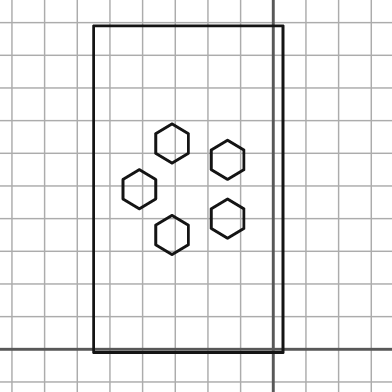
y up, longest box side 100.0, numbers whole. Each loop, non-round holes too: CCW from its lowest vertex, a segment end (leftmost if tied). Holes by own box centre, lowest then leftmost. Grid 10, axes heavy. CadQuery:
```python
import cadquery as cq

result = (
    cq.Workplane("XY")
    .moveTo(-55.0, -1.0)
    .lineTo(3.0, -1.0)
    .lineTo(3.0, 99.0)
    .lineTo(-55.0, 99.0)
    .close()
    .moveTo(-31.0, 29.0)
    .lineTo(-26.0, 32.0)
    .lineTo(-26.0, 38.0)
    .lineTo(-31.0, 41.0)
    .lineTo(-36.0, 38.0)
    .lineTo(-36.0, 32.0)
    .close()
    .moveTo(-14.0, 34.0)
    .lineTo(-9.0, 37.0)
    .lineTo(-9.0, 43.0)
    .lineTo(-14.0, 46.0)
    .lineTo(-19.0, 43.0)
    .lineTo(-19.0, 37.0)
    .close()
    .moveTo(-41.0, 43.0)
    .lineTo(-36.0, 46.0)
    .lineTo(-36.0, 52.0)
    .lineTo(-41.0, 55.0)
    .lineTo(-46.0, 52.0)
    .lineTo(-46.0, 46.0)
    .close()
    .moveTo(-14.0, 52.0)
    .lineTo(-9.0, 55.0)
    .lineTo(-9.0, 61.0)
    .lineTo(-14.0, 64.0)
    .lineTo(-19.0, 61.0)
    .lineTo(-19.0, 55.0)
    .close()
    .moveTo(-31.0, 57.0)
    .lineTo(-26.0, 60.0)
    .lineTo(-26.0, 66.0)
    .lineTo(-31.0, 69.0)
    .lineTo(-36.0, 66.0)
    .lineTo(-36.0, 60.0)
    .close()
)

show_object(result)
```